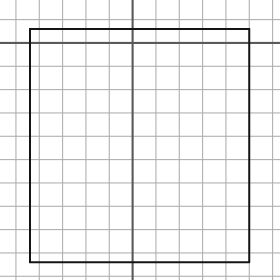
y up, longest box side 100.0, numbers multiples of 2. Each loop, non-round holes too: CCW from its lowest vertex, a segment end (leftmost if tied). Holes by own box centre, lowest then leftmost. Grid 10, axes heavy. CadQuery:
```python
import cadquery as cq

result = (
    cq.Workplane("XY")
    .moveTo(-44.0, -94.0)
    .lineTo(50.0, -94.0)
    .lineTo(50.0, 6.0)
    .lineTo(-44.0, 6.0)
    .close()
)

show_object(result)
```